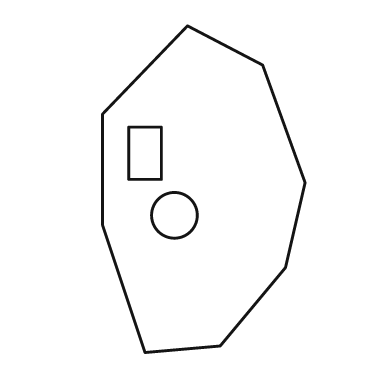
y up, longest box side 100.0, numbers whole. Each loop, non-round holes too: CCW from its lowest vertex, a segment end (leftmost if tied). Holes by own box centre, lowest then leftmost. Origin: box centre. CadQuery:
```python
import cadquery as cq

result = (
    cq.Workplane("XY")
    .moveTo(-18.0, -50.0)
    .lineTo(5.0, -48.0)
    .lineTo(25.0, -24.0)
    .lineTo(31.0, 2.0)
    .lineTo(18.0, 38.0)
    .lineTo(-5.0, 50.0)
    .lineTo(-31.0, 23.0)
    .lineTo(-31.0, -11.0)
    .close()
    .moveTo(-9.0, -8.0)
    .circle(7.0)
    .moveTo(-23.0, 3.0)
    .lineTo(-13.0, 3.0)
    .lineTo(-13.0, 19.0)
    .lineTo(-23.0, 19.0)
    .close()
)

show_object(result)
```